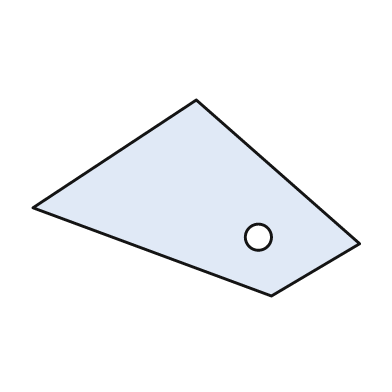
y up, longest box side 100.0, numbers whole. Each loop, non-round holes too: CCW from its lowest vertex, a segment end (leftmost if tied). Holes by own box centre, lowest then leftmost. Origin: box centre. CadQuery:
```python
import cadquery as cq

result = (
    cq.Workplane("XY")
    .moveTo(23.0, -30.0)
    .lineTo(50.0, -14.0)
    .lineTo(0.0, 30.0)
    .lineTo(-50.0, -3.0)
    .close()
    .moveTo(19.0, -12.0)
    .circle(4.0)
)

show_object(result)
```